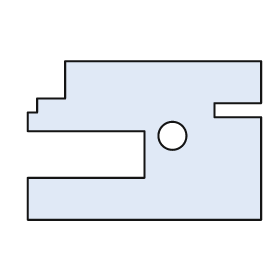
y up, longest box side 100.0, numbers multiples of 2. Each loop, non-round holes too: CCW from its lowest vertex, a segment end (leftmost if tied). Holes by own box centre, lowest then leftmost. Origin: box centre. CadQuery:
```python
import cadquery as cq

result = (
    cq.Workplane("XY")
    .moveTo(-50.0, -34.0)
    .lineTo(50.0, -34.0)
    .lineTo(50.0, 10.0)
    .lineTo(30.0, 10.0)
    .lineTo(30.0, 16.0)
    .lineTo(50.0, 16.0)
    .lineTo(50.0, 34.0)
    .lineTo(-34.0, 34.0)
    .lineTo(-34.0, 18.0)
    .lineTo(-46.0, 18.0)
    .lineTo(-46.0, 12.0)
    .lineTo(-50.0, 12.0)
    .lineTo(-50.0, 4.0)
    .lineTo(0.0, 4.0)
    .lineTo(0.0, -16.0)
    .lineTo(-50.0, -16.0)
    .close()
    .moveTo(12.0, 2.0)
    .circle(6.0)
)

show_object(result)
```